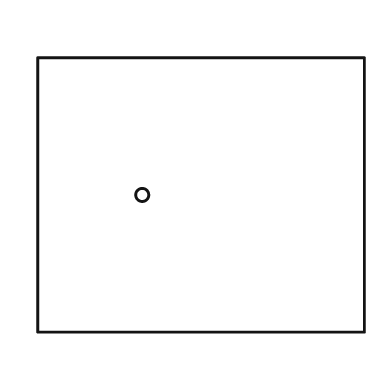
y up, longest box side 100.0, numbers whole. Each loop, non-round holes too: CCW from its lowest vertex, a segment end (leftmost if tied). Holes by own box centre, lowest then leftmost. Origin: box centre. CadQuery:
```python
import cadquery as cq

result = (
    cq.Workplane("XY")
    .moveTo(-50.0, -42.0)
    .lineTo(50.0, -42.0)
    .lineTo(50.0, 42.0)
    .lineTo(-50.0, 42.0)
    .close()
    .moveTo(-18.0, 0.0)
    .circle(2.0)
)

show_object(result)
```